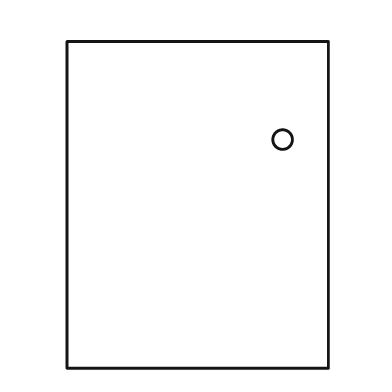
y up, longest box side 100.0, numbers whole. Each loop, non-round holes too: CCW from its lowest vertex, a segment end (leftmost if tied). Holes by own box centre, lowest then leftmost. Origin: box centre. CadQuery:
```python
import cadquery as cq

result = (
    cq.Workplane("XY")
    .moveTo(-40.0, -50.0)
    .lineTo(40.0, -50.0)
    .lineTo(40.0, 50.0)
    .lineTo(-40.0, 50.0)
    .close()
    .moveTo(26.0, 20.0)
    .circle(3.0)
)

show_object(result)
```